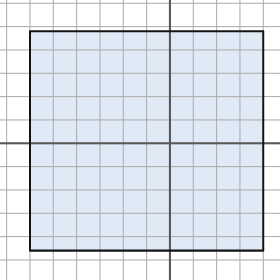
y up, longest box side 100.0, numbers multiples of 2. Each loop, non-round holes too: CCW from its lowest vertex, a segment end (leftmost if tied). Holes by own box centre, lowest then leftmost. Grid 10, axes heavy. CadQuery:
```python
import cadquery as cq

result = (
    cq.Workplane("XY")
    .moveTo(-60.0, -46.0)
    .lineTo(40.0, -46.0)
    .lineTo(40.0, 48.0)
    .lineTo(-60.0, 48.0)
    .close()
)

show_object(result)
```